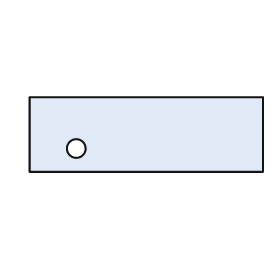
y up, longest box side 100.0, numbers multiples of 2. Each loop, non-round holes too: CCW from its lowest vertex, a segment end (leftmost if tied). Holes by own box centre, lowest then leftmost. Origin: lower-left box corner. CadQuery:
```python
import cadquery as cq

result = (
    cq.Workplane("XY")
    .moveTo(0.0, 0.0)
    .lineTo(100.0, 0.0)
    .lineTo(100.0, 32.0)
    .lineTo(0.0, 32.0)
    .close()
    .moveTo(20.0, 10.0)
    .circle(4.0)
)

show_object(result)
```